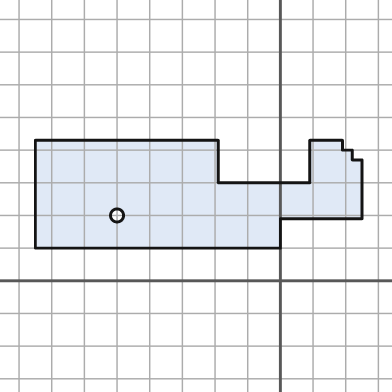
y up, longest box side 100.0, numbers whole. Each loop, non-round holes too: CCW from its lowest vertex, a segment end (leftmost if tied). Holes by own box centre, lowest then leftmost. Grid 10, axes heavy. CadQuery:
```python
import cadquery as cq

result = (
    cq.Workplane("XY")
    .moveTo(-75.0, 10.0)
    .lineTo(0.0, 10.0)
    .lineTo(0.0, 19.0)
    .lineTo(25.0, 19.0)
    .lineTo(25.0, 37.0)
    .lineTo(22.0, 37.0)
    .lineTo(22.0, 40.0)
    .lineTo(19.0, 40.0)
    .lineTo(19.0, 43.0)
    .lineTo(9.0, 43.0)
    .lineTo(9.0, 30.0)
    .lineTo(-19.0, 30.0)
    .lineTo(-19.0, 43.0)
    .lineTo(-75.0, 43.0)
    .close()
    .moveTo(-50.0, 20.0)
    .circle(2.0)
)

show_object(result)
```